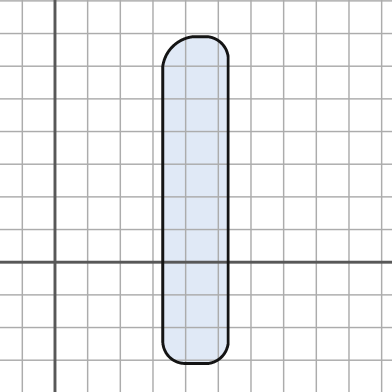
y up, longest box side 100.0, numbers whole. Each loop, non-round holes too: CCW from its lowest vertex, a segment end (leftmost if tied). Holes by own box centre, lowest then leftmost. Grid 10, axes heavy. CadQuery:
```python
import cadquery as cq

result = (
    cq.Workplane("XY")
    .moveTo(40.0, -31.0)
    .lineTo(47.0, -31.0)
    .threePointArc((51.0, -29.0), (53.0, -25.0))
    .lineTo(53.0, 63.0)
    .threePointArc((51.0, 67.0), (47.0, 69.0))
    .lineTo(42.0, 69.0)
    .threePointArc((36.0, 66.0), (33.0, 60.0))
    .lineTo(33.0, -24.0)
    .threePointArc((35.0, -29.0), (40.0, -31.0))
    .close()
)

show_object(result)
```